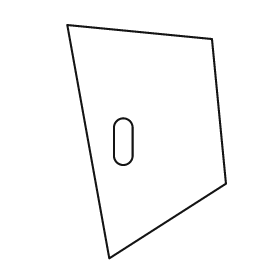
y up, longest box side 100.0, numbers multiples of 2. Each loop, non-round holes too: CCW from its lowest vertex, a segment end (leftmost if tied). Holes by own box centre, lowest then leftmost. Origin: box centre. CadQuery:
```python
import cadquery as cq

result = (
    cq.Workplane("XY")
    .moveTo(-16.0, -50.0)
    .lineTo(34.0, -18.0)
    .lineTo(28.0, 44.0)
    .lineTo(-34.0, 50.0)
    .close()
    .moveTo(-14.0, -6.0)
    .threePointArc((-10.0, -10.0), (-6.0, -6.0))
    .lineTo(-6.0, 6.0)
    .threePointArc((-10.0, 10.0), (-14.0, 6.0))
    .close()
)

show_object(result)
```